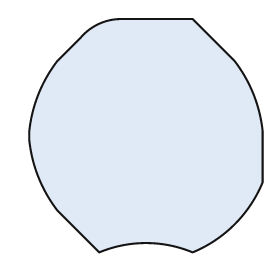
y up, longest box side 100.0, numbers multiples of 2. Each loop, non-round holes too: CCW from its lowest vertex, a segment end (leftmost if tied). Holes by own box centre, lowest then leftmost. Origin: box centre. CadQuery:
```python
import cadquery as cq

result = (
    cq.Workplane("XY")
    .moveTo(-20.0, -50.0)
    .threePointArc((0.0, -46.0), (20.0, -50.0))
    .threePointArc((38.0, -38.0), (50.0, -20.0))
    .lineTo(50.0, 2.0)
    .threePointArc((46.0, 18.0), (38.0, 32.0))
    .lineTo(20.0, 50.0)
    .lineTo(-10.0, 50.0)
    .threePointArc((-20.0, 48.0), (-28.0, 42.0))
    .lineTo(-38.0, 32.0)
    .threePointArc((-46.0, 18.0), (-50.0, 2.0))
    .lineTo(-50.0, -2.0)
    .threePointArc((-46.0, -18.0), (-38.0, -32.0))
    .close()
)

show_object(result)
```